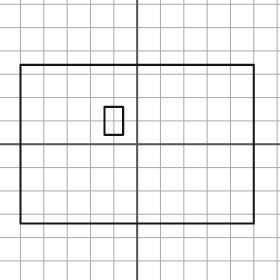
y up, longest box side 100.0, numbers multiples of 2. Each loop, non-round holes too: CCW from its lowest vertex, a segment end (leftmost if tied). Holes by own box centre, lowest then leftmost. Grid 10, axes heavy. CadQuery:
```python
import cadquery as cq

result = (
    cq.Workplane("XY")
    .moveTo(-50.0, -34.0)
    .lineTo(50.0, -34.0)
    .lineTo(50.0, 34.0)
    .lineTo(-50.0, 34.0)
    .close()
    .moveTo(-14.0, 4.0)
    .lineTo(-6.0, 4.0)
    .lineTo(-6.0, 16.0)
    .lineTo(-14.0, 16.0)
    .close()
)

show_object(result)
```